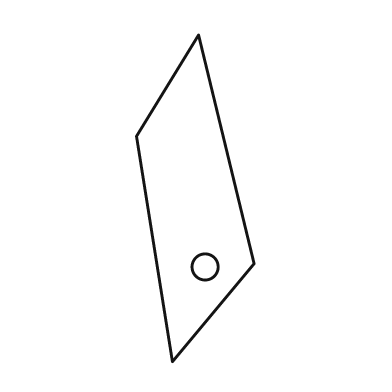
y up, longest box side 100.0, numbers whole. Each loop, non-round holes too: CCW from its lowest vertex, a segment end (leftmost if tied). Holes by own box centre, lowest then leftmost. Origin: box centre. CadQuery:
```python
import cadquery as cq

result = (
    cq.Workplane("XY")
    .moveTo(-7.0, -50.0)
    .lineTo(18.0, -20.0)
    .lineTo(1.0, 50.0)
    .lineTo(-18.0, 19.0)
    .close()
    .moveTo(3.0, -21.0)
    .circle(4.0)
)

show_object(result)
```